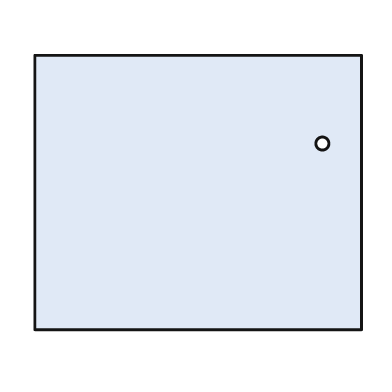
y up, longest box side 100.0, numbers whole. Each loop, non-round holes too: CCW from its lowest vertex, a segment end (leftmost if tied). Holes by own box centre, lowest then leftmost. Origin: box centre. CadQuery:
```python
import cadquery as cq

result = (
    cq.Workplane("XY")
    .moveTo(-50.0, -42.0)
    .lineTo(50.0, -42.0)
    .lineTo(50.0, 42.0)
    .lineTo(-50.0, 42.0)
    .close()
    .moveTo(38.0, 15.0)
    .circle(2.0)
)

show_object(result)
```